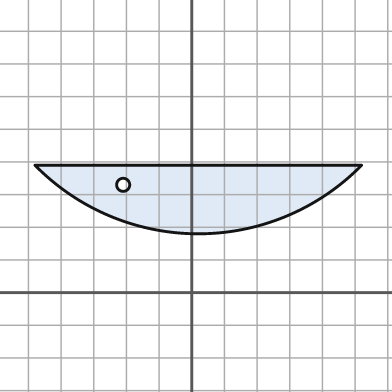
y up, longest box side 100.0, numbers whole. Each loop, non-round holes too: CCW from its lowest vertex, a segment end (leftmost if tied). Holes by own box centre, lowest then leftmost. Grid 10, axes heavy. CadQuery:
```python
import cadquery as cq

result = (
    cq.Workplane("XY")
    .moveTo(-48.0, 39.0)
    .threePointArc((2.0, 18.0), (52.0, 39.0))
    .close()
    .moveTo(-21.0, 33.0)
    .circle(2.0)
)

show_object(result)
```